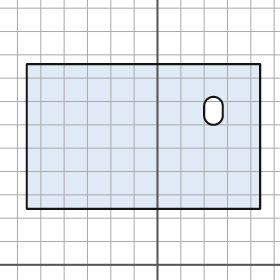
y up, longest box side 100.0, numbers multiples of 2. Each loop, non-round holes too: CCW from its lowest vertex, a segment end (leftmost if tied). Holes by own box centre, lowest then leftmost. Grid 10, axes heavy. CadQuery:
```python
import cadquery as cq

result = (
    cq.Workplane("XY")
    .moveTo(-56.0, 24.0)
    .lineTo(44.0, 24.0)
    .lineTo(44.0, 86.0)
    .lineTo(-56.0, 86.0)
    .close()
    .moveTo(20.0, 64.0)
    .threePointArc((24.0, 60.0), (28.0, 64.0))
    .lineTo(28.0, 68.0)
    .threePointArc((24.0, 72.0), (20.0, 68.0))
    .close()
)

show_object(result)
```